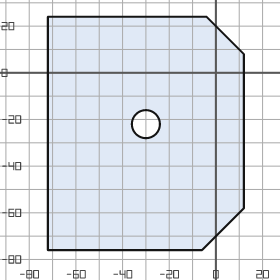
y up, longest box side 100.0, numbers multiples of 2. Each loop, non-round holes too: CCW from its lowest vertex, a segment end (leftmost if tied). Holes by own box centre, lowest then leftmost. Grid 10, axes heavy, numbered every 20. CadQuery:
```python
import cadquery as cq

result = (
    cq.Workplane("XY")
    .moveTo(-72.0, -76.0)
    .lineTo(-6.0, -76.0)
    .lineTo(12.0, -58.0)
    .lineTo(12.0, 8.0)
    .lineTo(-4.0, 24.0)
    .lineTo(-72.0, 24.0)
    .close()
    .moveTo(-30.0, -22.0)
    .circle(6.0)
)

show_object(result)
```